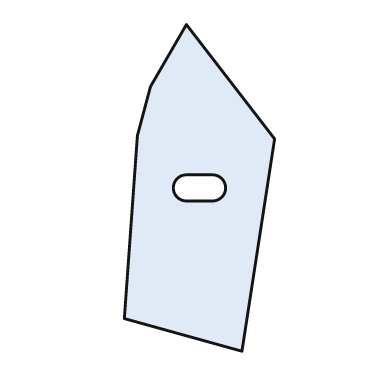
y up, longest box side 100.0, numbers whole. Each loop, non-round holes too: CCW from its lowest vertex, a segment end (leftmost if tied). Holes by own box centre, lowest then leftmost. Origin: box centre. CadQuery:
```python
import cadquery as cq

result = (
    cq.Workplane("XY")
    .moveTo(13.0, -50.0)
    .lineTo(23.0, 15.0)
    .lineTo(-4.0, 50.0)
    .lineTo(-15.0, 31.0)
    .lineTo(-19.0, 16.0)
    .lineTo(-23.0, -40.0)
    .close()
    .moveTo(-4.0, -4.0)
    .lineTo(4.0, -4.0)
    .threePointArc((8.0, 0.0), (4.0, 4.0))
    .lineTo(-4.0, 4.0)
    .threePointArc((-8.0, 0.0), (-4.0, -4.0))
    .close()
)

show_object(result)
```